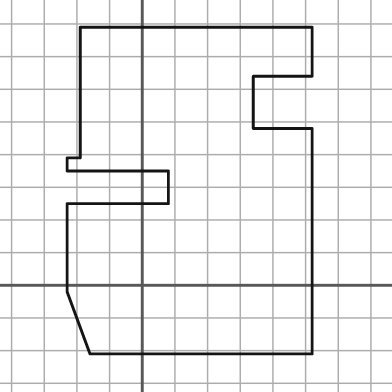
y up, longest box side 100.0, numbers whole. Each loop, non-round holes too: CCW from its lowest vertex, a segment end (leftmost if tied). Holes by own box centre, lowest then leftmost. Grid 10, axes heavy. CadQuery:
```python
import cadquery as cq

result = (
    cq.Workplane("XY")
    .moveTo(-16.0, -21.0)
    .lineTo(52.0, -21.0)
    .lineTo(52.0, 48.0)
    .lineTo(34.0, 48.0)
    .lineTo(34.0, 64.0)
    .lineTo(52.0, 64.0)
    .lineTo(52.0, 79.0)
    .lineTo(-19.0, 79.0)
    .lineTo(-19.0, 39.0)
    .lineTo(-23.0, 39.0)
    .lineTo(-23.0, 35.0)
    .lineTo(8.0, 35.0)
    .lineTo(8.0, 25.0)
    .lineTo(-23.0, 25.0)
    .lineTo(-23.0, -2.0)
    .close()
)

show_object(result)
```